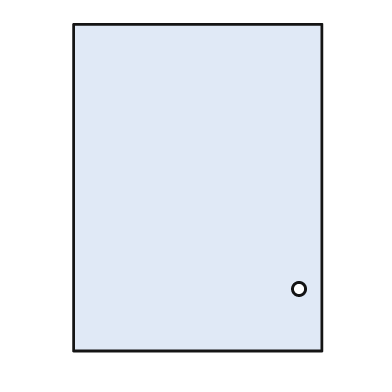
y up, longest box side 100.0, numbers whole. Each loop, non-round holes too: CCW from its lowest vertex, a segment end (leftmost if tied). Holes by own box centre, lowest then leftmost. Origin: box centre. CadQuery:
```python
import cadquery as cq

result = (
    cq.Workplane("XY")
    .moveTo(-38.0, -50.0)
    .lineTo(38.0, -50.0)
    .lineTo(38.0, 50.0)
    .lineTo(-38.0, 50.0)
    .close()
    .moveTo(31.0, -31.0)
    .circle(2.0)
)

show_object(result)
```